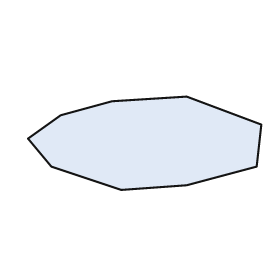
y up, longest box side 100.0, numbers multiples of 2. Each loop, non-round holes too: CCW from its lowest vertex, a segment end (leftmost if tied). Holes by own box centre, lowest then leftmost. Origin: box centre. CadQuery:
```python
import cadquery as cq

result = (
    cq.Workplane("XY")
    .moveTo(-10.0, -20.0)
    .lineTo(18.0, -18.0)
    .lineTo(48.0, -10.0)
    .lineTo(50.0, 8.0)
    .lineTo(18.0, 20.0)
    .lineTo(-14.0, 18.0)
    .lineTo(-36.0, 12.0)
    .lineTo(-50.0, 2.0)
    .lineTo(-40.0, -10.0)
    .close()
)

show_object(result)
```